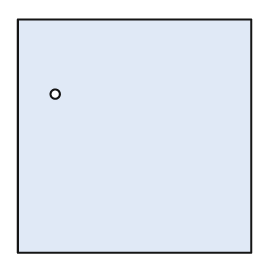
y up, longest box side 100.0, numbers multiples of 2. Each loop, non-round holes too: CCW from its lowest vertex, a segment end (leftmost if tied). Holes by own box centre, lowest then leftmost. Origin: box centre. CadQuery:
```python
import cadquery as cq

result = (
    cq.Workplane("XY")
    .moveTo(-50.0, -50.0)
    .lineTo(50.0, -50.0)
    .lineTo(50.0, 50.0)
    .lineTo(-50.0, 50.0)
    .close()
    .moveTo(-34.0, 18.0)
    .circle(2.0)
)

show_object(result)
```